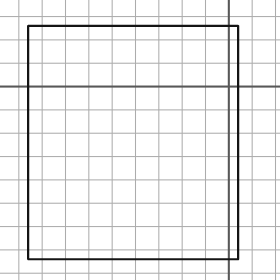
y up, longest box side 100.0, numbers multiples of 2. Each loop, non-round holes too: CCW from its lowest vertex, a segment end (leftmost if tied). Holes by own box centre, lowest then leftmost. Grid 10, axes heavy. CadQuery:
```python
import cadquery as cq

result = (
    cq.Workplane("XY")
    .moveTo(-86.0, -74.0)
    .lineTo(4.0, -74.0)
    .lineTo(4.0, 26.0)
    .lineTo(-86.0, 26.0)
    .close()
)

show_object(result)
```